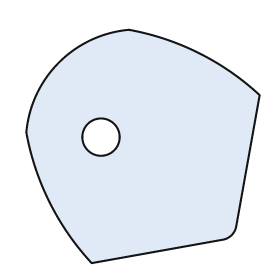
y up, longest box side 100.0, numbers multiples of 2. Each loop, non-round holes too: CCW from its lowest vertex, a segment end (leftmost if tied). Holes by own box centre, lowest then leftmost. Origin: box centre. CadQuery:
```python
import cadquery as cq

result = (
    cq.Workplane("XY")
    .moveTo(-22.0, -50.0)
    .lineTo(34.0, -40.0)
    .threePointArc((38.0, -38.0), (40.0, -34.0))
    .lineTo(50.0, 22.0)
    .threePointArc((24.0, 40.0), (-6.0, 50.0))
    .threePointArc((-36.0, 36.0), (-50.0, 6.0))
    .threePointArc((-40.0, -24.0), (-22.0, -50.0))
    .close()
    .moveTo(-18.0, 4.0)
    .circle(8.0)
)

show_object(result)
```